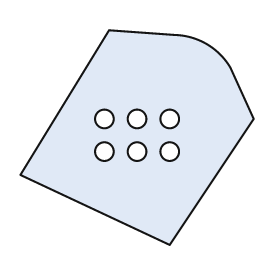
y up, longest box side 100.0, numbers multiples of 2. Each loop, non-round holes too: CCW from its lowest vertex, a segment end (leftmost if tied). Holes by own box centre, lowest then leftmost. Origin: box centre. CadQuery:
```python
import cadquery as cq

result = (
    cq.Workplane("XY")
    .moveTo(14.0, -46.0)
    .lineTo(50.0, 8.0)
    .lineTo(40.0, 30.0)
    .threePointArc((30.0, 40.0), (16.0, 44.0))
    .lineTo(-12.0, 46.0)
    .lineTo(-50.0, -16.0)
    .close()
    .moveTo(-14.0, -6.0)
    .circle(4.0)
    .moveTo(0.0, -6.0)
    .circle(4.0)
    .moveTo(14.0, -6.0)
    .circle(4.0)
    .moveTo(-14.0, 8.0)
    .circle(4.0)
    .moveTo(0.0, 8.0)
    .circle(4.0)
    .moveTo(14.0, 8.0)
    .circle(4.0)
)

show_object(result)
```